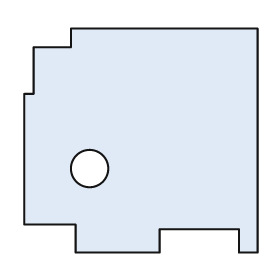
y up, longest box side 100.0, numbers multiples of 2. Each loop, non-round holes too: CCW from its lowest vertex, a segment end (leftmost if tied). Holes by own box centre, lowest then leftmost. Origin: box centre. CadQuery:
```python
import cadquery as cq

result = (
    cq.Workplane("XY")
    .moveTo(-28.0, -48.0)
    .lineTo(8.0, -48.0)
    .lineTo(8.0, -38.0)
    .lineTo(42.0, -38.0)
    .lineTo(42.0, -48.0)
    .lineTo(50.0, -48.0)
    .lineTo(50.0, 48.0)
    .lineTo(-30.0, 48.0)
    .lineTo(-30.0, 40.0)
    .lineTo(-46.0, 40.0)
    .lineTo(-46.0, 20.0)
    .lineTo(-50.0, 20.0)
    .lineTo(-50.0, -36.0)
    .lineTo(-28.0, -36.0)
    .close()
    .moveTo(-22.0, -12.0)
    .circle(8.0)
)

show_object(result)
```